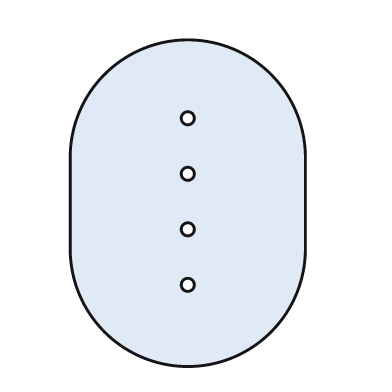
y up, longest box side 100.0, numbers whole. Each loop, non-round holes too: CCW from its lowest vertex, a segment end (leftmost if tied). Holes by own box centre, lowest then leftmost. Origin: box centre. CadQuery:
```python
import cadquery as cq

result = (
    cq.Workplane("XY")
    .moveTo(-36.0, -14.0)
    .threePointArc((0.0, -50.0), (36.0, -14.0))
    .lineTo(36.0, 14.0)
    .threePointArc((0.0, 50.0), (-36.0, 14.0))
    .close()
    .moveTo(0.0, -25.0)
    .circle(2.0)
    .moveTo(0.0, -8.0)
    .circle(2.0)
    .moveTo(0.0, 9.0)
    .circle(2.0)
    .moveTo(0.0, 26.0)
    .circle(2.0)
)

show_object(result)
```